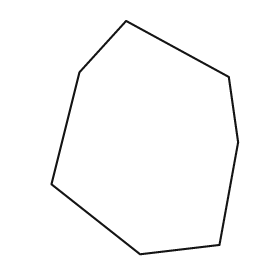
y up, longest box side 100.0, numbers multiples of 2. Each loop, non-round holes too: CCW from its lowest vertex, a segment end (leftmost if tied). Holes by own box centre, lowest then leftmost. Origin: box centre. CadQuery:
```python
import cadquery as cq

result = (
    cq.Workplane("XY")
    .moveTo(-2.0, -50.0)
    .lineTo(32.0, -46.0)
    .lineTo(40.0, -2.0)
    .lineTo(36.0, 26.0)
    .lineTo(-8.0, 50.0)
    .lineTo(-28.0, 28.0)
    .lineTo(-40.0, -20.0)
    .close()
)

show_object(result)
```